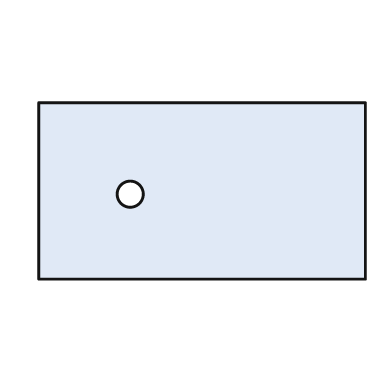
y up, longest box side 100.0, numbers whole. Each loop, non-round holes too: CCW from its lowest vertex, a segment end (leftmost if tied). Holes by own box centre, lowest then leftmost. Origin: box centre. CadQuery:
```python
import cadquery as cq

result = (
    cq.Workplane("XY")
    .moveTo(-50.0, -27.0)
    .lineTo(50.0, -27.0)
    .lineTo(50.0, 27.0)
    .lineTo(-50.0, 27.0)
    .close()
    .moveTo(-22.0, -1.0)
    .circle(4.0)
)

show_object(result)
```